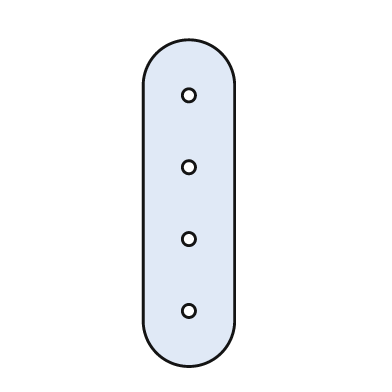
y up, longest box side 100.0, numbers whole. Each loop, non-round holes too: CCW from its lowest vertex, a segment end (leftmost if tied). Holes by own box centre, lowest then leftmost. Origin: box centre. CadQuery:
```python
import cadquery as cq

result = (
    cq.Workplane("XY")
    .moveTo(-14.0, -36.0)
    .threePointArc((0.0, -50.0), (14.0, -36.0))
    .lineTo(14.0, 36.0)
    .threePointArc((0.0, 50.0), (-14.0, 36.0))
    .close()
    .moveTo(0.0, -33.0)
    .circle(2.0)
    .moveTo(0.0, -11.0)
    .circle(2.0)
    .moveTo(0.0, 11.0)
    .circle(2.0)
    .moveTo(0.0, 33.0)
    .circle(2.0)
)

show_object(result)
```